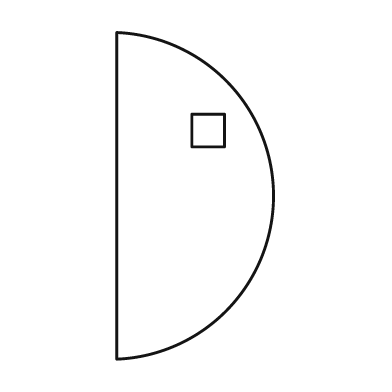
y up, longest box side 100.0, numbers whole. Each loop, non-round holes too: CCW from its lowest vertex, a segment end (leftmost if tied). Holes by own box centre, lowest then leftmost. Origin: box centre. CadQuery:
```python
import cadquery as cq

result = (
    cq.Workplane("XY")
    .moveTo(-24.0, -50.0)
    .threePointArc((24.0, 0.0), (-24.0, 50.0))
    .close()
    .moveTo(-1.0, 15.0)
    .lineTo(9.0, 15.0)
    .lineTo(9.0, 25.0)
    .lineTo(-1.0, 25.0)
    .close()
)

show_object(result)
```